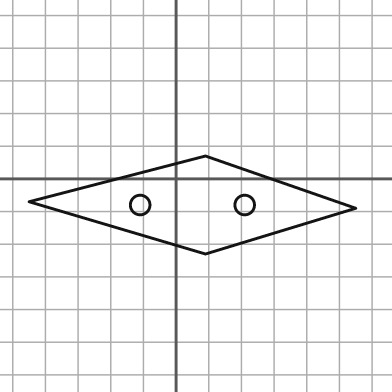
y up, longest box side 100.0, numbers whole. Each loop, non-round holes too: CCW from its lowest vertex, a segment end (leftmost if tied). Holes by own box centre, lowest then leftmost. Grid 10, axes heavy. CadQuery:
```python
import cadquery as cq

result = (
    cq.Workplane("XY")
    .moveTo(9.0, -23.0)
    .lineTo(55.0, -9.0)
    .lineTo(9.0, 7.0)
    .lineTo(-45.0, -7.0)
    .close()
    .moveTo(-11.0, -8.0)
    .circle(3.0)
    .moveTo(21.0, -8.0)
    .circle(3.0)
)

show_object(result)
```